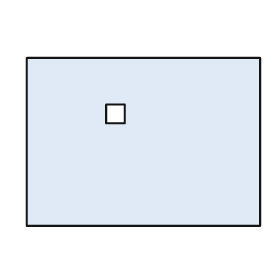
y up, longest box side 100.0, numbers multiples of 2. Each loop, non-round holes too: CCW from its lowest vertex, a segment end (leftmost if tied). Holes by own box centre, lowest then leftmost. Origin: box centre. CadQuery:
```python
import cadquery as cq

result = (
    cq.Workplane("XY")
    .moveTo(-50.0, -36.0)
    .lineTo(50.0, -36.0)
    .lineTo(50.0, 36.0)
    .lineTo(-50.0, 36.0)
    .close()
    .moveTo(-16.0, 8.0)
    .lineTo(-8.0, 8.0)
    .lineTo(-8.0, 16.0)
    .lineTo(-16.0, 16.0)
    .close()
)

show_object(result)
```